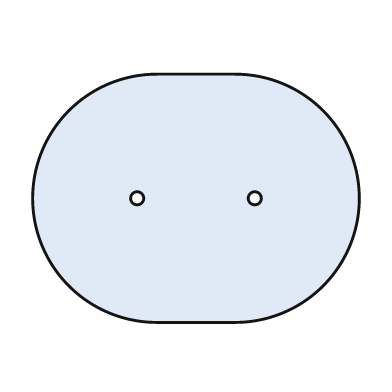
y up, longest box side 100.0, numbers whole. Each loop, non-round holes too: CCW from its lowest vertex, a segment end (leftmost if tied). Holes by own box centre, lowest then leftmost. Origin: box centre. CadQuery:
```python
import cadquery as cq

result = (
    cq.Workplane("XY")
    .moveTo(-12.0, -38.0)
    .lineTo(12.0, -38.0)
    .threePointArc((50.0, 0.0), (12.0, 38.0))
    .lineTo(-12.0, 38.0)
    .threePointArc((-50.0, 0.0), (-12.0, -38.0))
    .close()
    .moveTo(-18.0, 0.0)
    .circle(2.0)
    .moveTo(18.0, 0.0)
    .circle(2.0)
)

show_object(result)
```